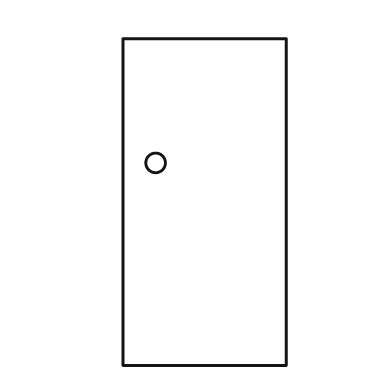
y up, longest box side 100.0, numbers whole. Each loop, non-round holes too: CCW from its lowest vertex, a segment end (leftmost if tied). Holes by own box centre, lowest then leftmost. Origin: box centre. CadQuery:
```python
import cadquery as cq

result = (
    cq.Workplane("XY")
    .moveTo(-25.0, -50.0)
    .lineTo(25.0, -50.0)
    .lineTo(25.0, 50.0)
    .lineTo(-25.0, 50.0)
    .close()
    .moveTo(-15.0, 12.0)
    .circle(3.0)
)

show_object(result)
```